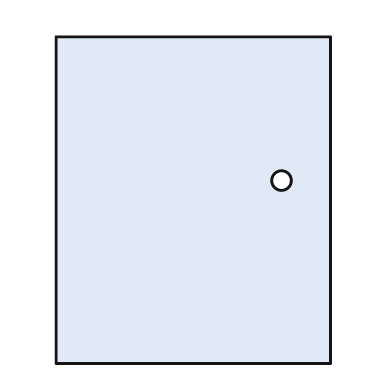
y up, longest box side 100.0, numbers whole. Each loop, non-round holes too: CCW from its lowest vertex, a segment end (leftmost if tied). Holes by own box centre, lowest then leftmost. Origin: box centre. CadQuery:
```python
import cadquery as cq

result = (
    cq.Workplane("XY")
    .moveTo(-42.0, -50.0)
    .lineTo(42.0, -50.0)
    .lineTo(42.0, 50.0)
    .lineTo(-42.0, 50.0)
    .close()
    .moveTo(27.0, 6.0)
    .circle(3.0)
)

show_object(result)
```